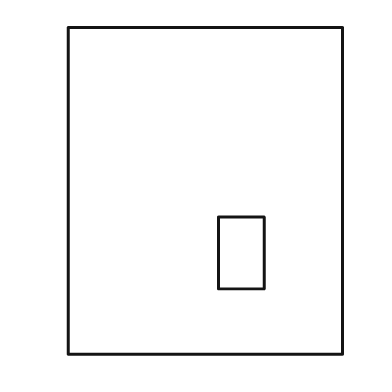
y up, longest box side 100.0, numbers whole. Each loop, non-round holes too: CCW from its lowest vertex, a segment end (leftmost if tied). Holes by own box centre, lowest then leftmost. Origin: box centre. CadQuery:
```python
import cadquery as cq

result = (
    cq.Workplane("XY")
    .moveTo(-42.0, -50.0)
    .lineTo(42.0, -50.0)
    .lineTo(42.0, 50.0)
    .lineTo(-42.0, 50.0)
    .close()
    .moveTo(4.0, -30.0)
    .lineTo(18.0, -30.0)
    .lineTo(18.0, -8.0)
    .lineTo(4.0, -8.0)
    .close()
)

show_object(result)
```